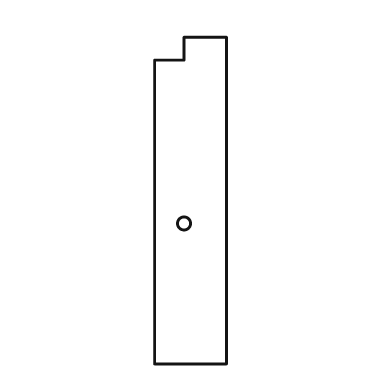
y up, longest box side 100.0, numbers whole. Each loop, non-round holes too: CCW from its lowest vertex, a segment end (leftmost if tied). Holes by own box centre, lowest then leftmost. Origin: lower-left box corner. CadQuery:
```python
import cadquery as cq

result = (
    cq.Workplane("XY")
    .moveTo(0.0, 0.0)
    .lineTo(22.0, 0.0)
    .lineTo(22.0, 100.0)
    .lineTo(9.0, 100.0)
    .lineTo(9.0, 93.0)
    .lineTo(0.0, 93.0)
    .close()
    .moveTo(9.0, 43.0)
    .circle(2.0)
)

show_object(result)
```